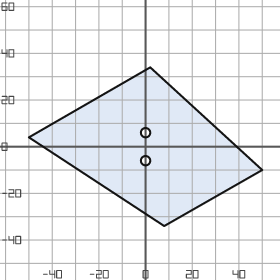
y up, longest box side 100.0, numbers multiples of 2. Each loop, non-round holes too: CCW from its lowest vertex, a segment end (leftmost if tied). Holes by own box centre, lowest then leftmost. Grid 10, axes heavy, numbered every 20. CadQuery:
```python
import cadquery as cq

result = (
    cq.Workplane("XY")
    .moveTo(8.0, -34.0)
    .lineTo(50.0, -10.0)
    .lineTo(2.0, 34.0)
    .lineTo(-50.0, 4.0)
    .close()
    .moveTo(0.0, -6.0)
    .circle(2.0)
    .moveTo(0.0, 6.0)
    .circle(2.0)
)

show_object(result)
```